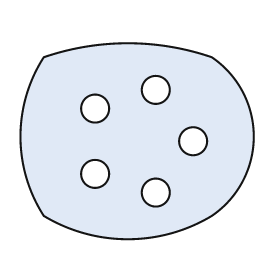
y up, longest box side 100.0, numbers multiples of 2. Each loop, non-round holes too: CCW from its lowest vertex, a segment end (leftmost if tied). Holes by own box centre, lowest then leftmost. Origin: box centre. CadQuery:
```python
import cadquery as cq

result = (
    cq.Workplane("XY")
    .moveTo(-40.0, -32.0)
    .threePointArc((-4.0, -42.0), (32.0, -32.0))
    .threePointArc((50.0, 2.0), (32.0, 36.0))
    .threePointArc((-4.0, 42.0), (-40.0, 36.0))
    .threePointArc((-50.0, 2.0), (-40.0, -32.0))
    .close()
    .moveTo(8.0, -22.0)
    .circle(6.0)
    .moveTo(-18.0, -14.0)
    .circle(6.0)
    .moveTo(24.0, 0.0)
    .circle(6.0)
    .moveTo(-18.0, 14.0)
    .circle(6.0)
    .moveTo(8.0, 22.0)
    .circle(6.0)
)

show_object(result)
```